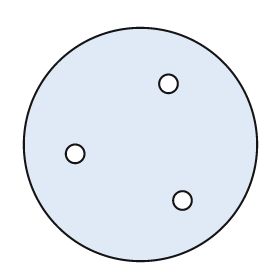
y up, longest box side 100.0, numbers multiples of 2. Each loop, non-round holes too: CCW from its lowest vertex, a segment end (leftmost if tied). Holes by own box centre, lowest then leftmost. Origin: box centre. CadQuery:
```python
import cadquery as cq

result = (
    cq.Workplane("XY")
    .moveTo(0.0, 0.0)
    .circle(50.0)
    .moveTo(18.0, -24.0)
    .circle(4.0)
    .moveTo(-28.0, -4.0)
    .circle(4.0)
    .moveTo(12.0, 26.0)
    .circle(4.0)
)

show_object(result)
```